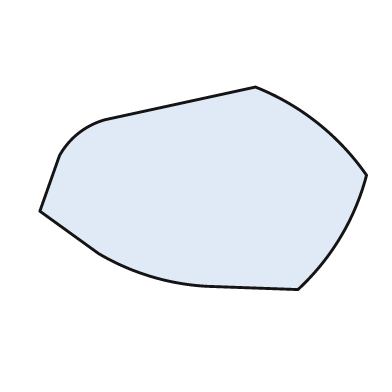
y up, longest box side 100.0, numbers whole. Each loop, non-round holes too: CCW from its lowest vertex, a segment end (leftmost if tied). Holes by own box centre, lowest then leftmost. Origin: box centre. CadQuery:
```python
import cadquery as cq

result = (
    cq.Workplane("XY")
    .moveTo(29.0, -31.0)
    .threePointArc((42.0, -15.0), (50.0, 4.0))
    .threePointArc((35.0, 20.0), (16.0, 31.0))
    .lineTo(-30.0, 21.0)
    .threePointArc((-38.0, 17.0), (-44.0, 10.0))
    .lineTo(-50.0, -7.0)
    .lineTo(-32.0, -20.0)
    .threePointArc((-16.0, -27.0), (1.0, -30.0))
    .close()
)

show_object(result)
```